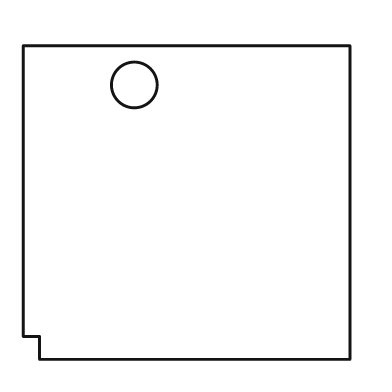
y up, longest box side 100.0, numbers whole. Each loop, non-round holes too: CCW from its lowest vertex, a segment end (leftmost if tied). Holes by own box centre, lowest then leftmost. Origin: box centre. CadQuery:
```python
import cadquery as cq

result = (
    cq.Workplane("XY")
    .moveTo(-45.0, -48.0)
    .lineTo(50.0, -48.0)
    .lineTo(50.0, 48.0)
    .lineTo(-50.0, 48.0)
    .lineTo(-50.0, -41.0)
    .lineTo(-45.0, -41.0)
    .close()
    .moveTo(-16.0, 36.0)
    .circle(7.0)
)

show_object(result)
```